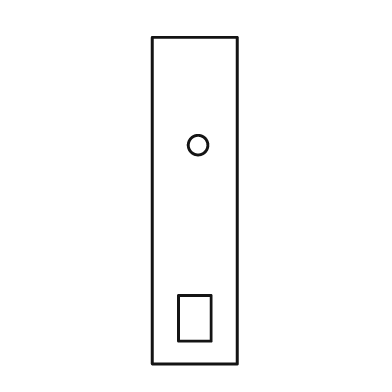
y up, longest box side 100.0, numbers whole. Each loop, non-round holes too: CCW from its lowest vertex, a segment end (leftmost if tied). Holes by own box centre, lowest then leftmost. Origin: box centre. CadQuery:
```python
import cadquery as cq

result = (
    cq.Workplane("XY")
    .moveTo(-13.0, -50.0)
    .lineTo(13.0, -50.0)
    .lineTo(13.0, 50.0)
    .lineTo(-13.0, 50.0)
    .close()
    .moveTo(-5.0, -43.0)
    .lineTo(5.0, -43.0)
    .lineTo(5.0, -29.0)
    .lineTo(-5.0, -29.0)
    .close()
    .moveTo(1.0, 17.0)
    .circle(3.0)
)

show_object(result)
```